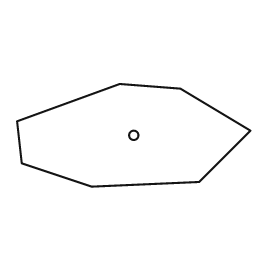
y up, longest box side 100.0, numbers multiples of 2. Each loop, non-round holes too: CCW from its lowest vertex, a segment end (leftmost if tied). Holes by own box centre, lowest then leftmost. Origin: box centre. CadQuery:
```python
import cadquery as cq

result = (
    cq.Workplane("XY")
    .moveTo(-18.0, -22.0)
    .lineTo(28.0, -20.0)
    .lineTo(50.0, 2.0)
    .lineTo(20.0, 20.0)
    .lineTo(-6.0, 22.0)
    .lineTo(-50.0, 6.0)
    .lineTo(-48.0, -12.0)
    .close()
    .moveTo(0.0, 0.0)
    .circle(2.0)
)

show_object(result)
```